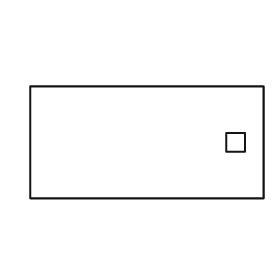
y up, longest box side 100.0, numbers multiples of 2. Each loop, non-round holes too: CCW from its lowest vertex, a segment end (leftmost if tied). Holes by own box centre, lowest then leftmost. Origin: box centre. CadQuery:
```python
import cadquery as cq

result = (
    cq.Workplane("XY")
    .moveTo(-50.0, -24.0)
    .lineTo(50.0, -24.0)
    .lineTo(50.0, 24.0)
    .lineTo(-50.0, 24.0)
    .close()
    .moveTo(34.0, -4.0)
    .lineTo(42.0, -4.0)
    .lineTo(42.0, 4.0)
    .lineTo(34.0, 4.0)
    .close()
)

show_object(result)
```